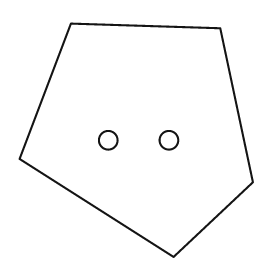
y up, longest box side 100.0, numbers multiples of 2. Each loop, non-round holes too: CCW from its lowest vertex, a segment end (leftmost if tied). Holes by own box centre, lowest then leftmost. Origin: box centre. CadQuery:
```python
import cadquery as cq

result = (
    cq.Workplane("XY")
    .moveTo(16.0, -50.0)
    .lineTo(50.0, -18.0)
    .lineTo(36.0, 48.0)
    .lineTo(-28.0, 50.0)
    .lineTo(-50.0, -8.0)
    .close()
    .moveTo(-12.0, 0.0)
    .circle(4.0)
    .moveTo(14.0, 0.0)
    .circle(4.0)
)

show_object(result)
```